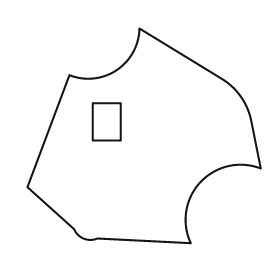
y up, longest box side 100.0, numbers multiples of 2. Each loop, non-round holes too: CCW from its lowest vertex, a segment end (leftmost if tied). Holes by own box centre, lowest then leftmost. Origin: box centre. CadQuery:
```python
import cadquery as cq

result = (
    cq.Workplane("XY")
    .moveTo(20.0, -46.0)
    .threePointArc((24.0, -20.0), (50.0, -14.0))
    .lineTo(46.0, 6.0)
    .threePointArc((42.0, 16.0), (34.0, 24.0))
    .lineTo(-2.0, 46.0)
    .threePointArc((-12.0, 28.0), (-32.0, 26.0))
    .lineTo(-50.0, -22.0)
    .lineTo(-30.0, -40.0)
    .threePointArc((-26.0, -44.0), (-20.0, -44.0))
    .close()
    .moveTo(-22.0, -2.0)
    .lineTo(-10.0, -2.0)
    .lineTo(-10.0, 14.0)
    .lineTo(-22.0, 14.0)
    .close()
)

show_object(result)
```